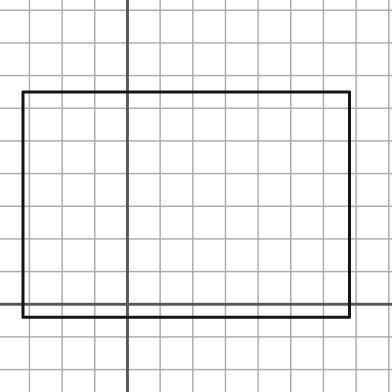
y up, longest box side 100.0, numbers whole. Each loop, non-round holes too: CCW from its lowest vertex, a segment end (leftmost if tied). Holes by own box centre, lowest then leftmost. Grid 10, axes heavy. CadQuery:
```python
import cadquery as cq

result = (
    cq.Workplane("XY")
    .moveTo(-32.0, -4.0)
    .lineTo(68.0, -4.0)
    .lineTo(68.0, 65.0)
    .lineTo(-32.0, 65.0)
    .close()
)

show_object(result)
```